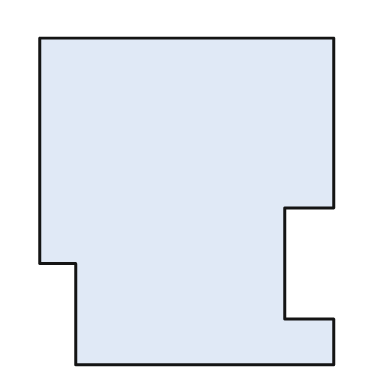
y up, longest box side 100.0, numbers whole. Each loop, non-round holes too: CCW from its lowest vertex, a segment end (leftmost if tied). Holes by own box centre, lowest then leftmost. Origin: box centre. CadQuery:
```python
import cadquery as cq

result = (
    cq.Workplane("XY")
    .moveTo(-34.0, -50.0)
    .lineTo(45.0, -50.0)
    .lineTo(45.0, -36.0)
    .lineTo(30.0, -36.0)
    .lineTo(30.0, -2.0)
    .lineTo(45.0, -2.0)
    .lineTo(45.0, 50.0)
    .lineTo(-45.0, 50.0)
    .lineTo(-45.0, -19.0)
    .lineTo(-34.0, -19.0)
    .close()
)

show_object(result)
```